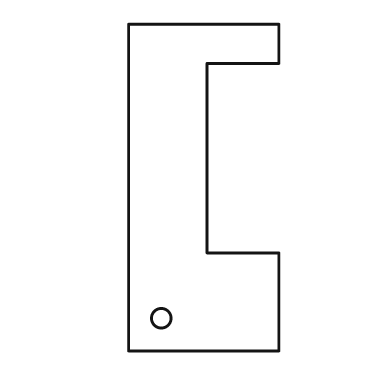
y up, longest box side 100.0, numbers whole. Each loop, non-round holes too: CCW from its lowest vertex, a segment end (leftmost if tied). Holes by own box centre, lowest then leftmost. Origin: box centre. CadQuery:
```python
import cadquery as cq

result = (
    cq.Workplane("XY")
    .moveTo(-23.0, -50.0)
    .lineTo(23.0, -50.0)
    .lineTo(23.0, -20.0)
    .lineTo(1.0, -20.0)
    .lineTo(1.0, 38.0)
    .lineTo(23.0, 38.0)
    .lineTo(23.0, 50.0)
    .lineTo(-23.0, 50.0)
    .close()
    .moveTo(-13.0, -40.0)
    .circle(3.0)
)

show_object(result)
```